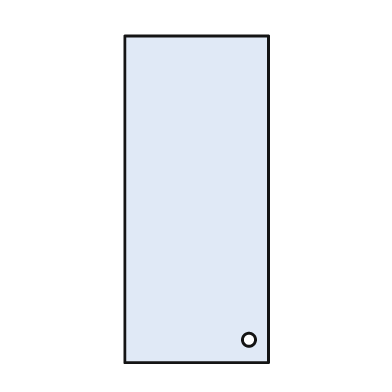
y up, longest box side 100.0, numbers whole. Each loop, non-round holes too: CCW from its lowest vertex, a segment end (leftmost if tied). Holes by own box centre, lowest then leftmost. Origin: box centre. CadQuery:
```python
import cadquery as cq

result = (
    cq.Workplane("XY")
    .moveTo(-22.0, -50.0)
    .lineTo(22.0, -50.0)
    .lineTo(22.0, 50.0)
    .lineTo(-22.0, 50.0)
    .close()
    .moveTo(16.0, -43.0)
    .circle(2.0)
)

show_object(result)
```